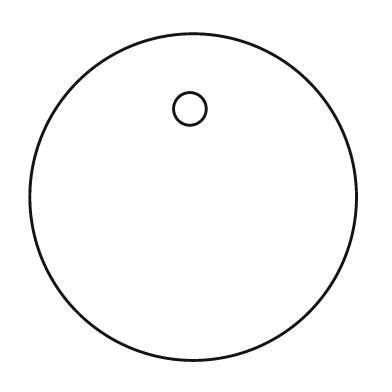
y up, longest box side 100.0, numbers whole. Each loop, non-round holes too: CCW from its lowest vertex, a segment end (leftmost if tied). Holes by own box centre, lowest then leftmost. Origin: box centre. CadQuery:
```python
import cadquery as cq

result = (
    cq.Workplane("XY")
    .moveTo(0.0, 0.0)
    .circle(50.0)
    .moveTo(-1.0, 27.0)
    .circle(5.0)
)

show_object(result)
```